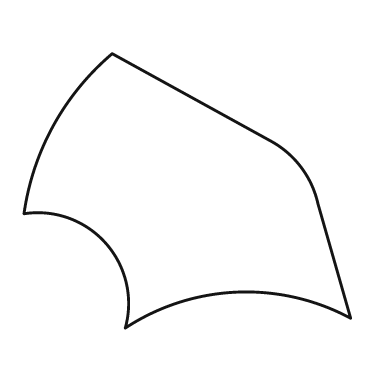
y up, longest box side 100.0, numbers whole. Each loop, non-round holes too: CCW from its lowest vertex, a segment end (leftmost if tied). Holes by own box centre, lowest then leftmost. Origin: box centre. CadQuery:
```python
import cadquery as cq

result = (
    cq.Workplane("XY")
    .moveTo(-19.0, -42.0)
    .threePointArc((15.0, -31.0), (50.0, -39.0))
    .lineTo(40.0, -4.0)
    .threePointArc((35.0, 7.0), (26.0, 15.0))
    .lineTo(-23.0, 42.0)
    .threePointArc((-41.0, 20.0), (-50.0, -7.0))
    .threePointArc((-25.0, -16.0), (-19.0, -42.0))
    .close()
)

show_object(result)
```